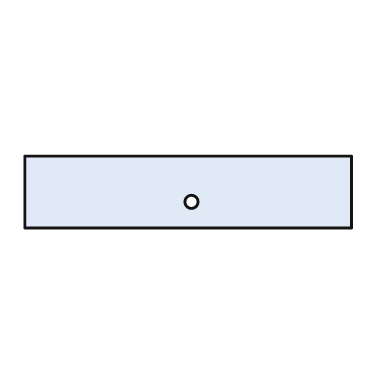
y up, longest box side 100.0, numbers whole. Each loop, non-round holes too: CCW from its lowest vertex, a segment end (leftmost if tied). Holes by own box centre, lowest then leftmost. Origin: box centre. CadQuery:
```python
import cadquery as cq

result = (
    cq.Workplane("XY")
    .moveTo(-50.0, -11.0)
    .lineTo(50.0, -11.0)
    .lineTo(50.0, 11.0)
    .lineTo(-50.0, 11.0)
    .close()
    .moveTo(1.0, -3.0)
    .circle(2.0)
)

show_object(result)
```